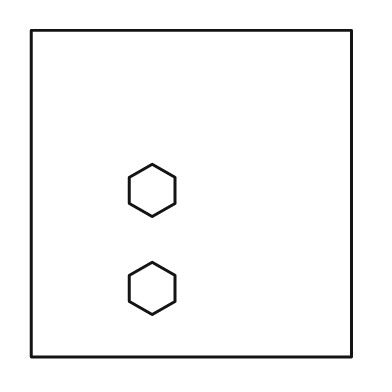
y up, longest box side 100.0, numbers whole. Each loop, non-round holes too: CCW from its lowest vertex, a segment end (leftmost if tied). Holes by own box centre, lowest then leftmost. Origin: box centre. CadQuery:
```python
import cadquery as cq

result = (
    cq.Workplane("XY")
    .moveTo(-49.0, -50.0)
    .lineTo(49.0, -50.0)
    .lineTo(49.0, 50.0)
    .lineTo(-49.0, 50.0)
    .close()
    .moveTo(-12.0, -37.0)
    .lineTo(-5.0, -33.0)
    .lineTo(-5.0, -25.0)
    .lineTo(-12.0, -21.0)
    .lineTo(-19.0, -25.0)
    .lineTo(-19.0, -33.0)
    .close()
    .moveTo(-12.0, -7.0)
    .lineTo(-5.0, -3.0)
    .lineTo(-5.0, 5.0)
    .lineTo(-12.0, 9.0)
    .lineTo(-19.0, 5.0)
    .lineTo(-19.0, -3.0)
    .close()
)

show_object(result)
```